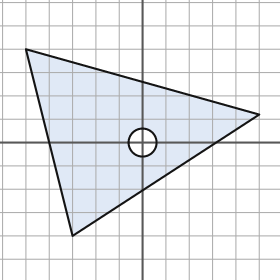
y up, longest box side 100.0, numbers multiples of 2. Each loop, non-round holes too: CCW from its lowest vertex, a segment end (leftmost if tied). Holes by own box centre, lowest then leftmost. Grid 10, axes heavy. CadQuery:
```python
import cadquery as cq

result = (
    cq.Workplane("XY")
    .moveTo(-30.0, -40.0)
    .lineTo(50.0, 12.0)
    .lineTo(-50.0, 40.0)
    .close()
    .moveTo(0.0, 0.0)
    .circle(6.0)
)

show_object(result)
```